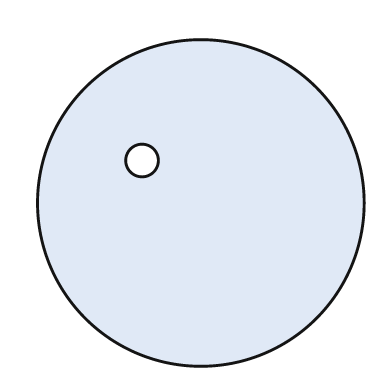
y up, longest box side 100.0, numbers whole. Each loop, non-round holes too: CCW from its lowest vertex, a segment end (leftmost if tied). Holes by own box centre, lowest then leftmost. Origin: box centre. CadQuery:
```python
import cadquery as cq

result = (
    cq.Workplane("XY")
    .moveTo(0.0, 0.0)
    .circle(50.0)
    .moveTo(-18.0, 13.0)
    .circle(5.0)
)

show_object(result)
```